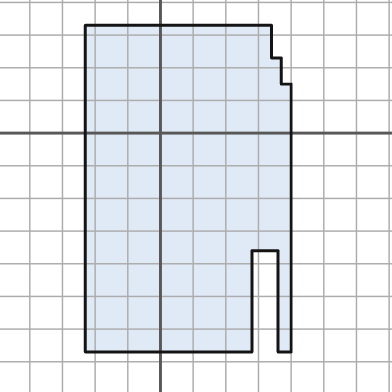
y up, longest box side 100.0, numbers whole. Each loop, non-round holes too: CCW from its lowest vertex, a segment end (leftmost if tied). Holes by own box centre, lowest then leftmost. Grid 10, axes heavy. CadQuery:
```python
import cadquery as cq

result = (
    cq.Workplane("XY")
    .moveTo(-23.0, -67.0)
    .lineTo(28.0, -67.0)
    .lineTo(28.0, -36.0)
    .lineTo(36.0, -36.0)
    .lineTo(36.0, -67.0)
    .lineTo(40.0, -67.0)
    .lineTo(40.0, 15.0)
    .lineTo(37.0, 15.0)
    .lineTo(37.0, 23.0)
    .lineTo(34.0, 23.0)
    .lineTo(34.0, 33.0)
    .lineTo(-23.0, 33.0)
    .close()
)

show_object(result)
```